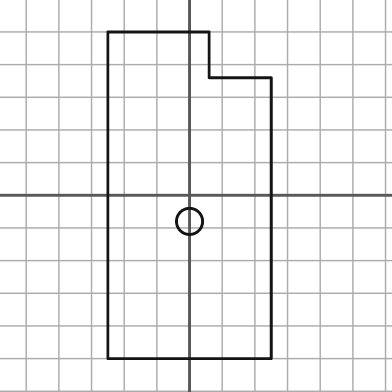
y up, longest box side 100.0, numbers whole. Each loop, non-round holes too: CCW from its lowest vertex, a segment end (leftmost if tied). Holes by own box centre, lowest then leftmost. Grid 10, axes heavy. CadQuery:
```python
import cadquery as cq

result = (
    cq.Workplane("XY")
    .moveTo(-25.0, -50.0)
    .lineTo(25.0, -50.0)
    .lineTo(25.0, 36.0)
    .lineTo(6.0, 36.0)
    .lineTo(6.0, 50.0)
    .lineTo(-25.0, 50.0)
    .close()
    .moveTo(0.0, -8.0)
    .circle(4.0)
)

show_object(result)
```